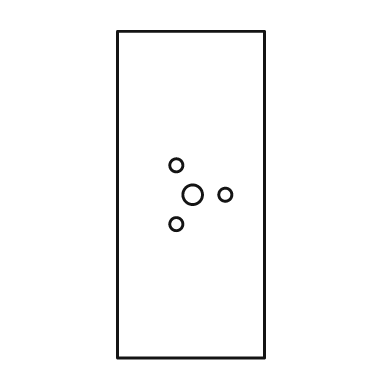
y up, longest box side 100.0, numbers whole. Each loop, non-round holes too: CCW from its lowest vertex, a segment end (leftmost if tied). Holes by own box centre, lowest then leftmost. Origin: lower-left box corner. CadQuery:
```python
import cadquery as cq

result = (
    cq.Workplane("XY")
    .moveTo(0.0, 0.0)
    .lineTo(45.0, 0.0)
    .lineTo(45.0, 100.0)
    .lineTo(0.0, 100.0)
    .close()
    .moveTo(18.0, 41.0)
    .circle(2.0)
    .moveTo(23.0, 50.0)
    .circle(3.0)
    .moveTo(33.0, 50.0)
    .circle(2.0)
    .moveTo(18.0, 59.0)
    .circle(2.0)
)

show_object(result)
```